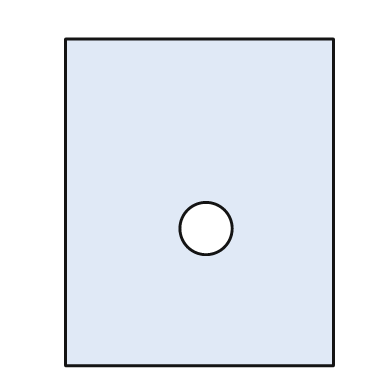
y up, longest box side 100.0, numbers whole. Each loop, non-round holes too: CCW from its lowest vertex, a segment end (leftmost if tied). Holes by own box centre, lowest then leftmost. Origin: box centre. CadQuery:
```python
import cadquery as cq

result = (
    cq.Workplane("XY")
    .moveTo(-41.0, -50.0)
    .lineTo(41.0, -50.0)
    .lineTo(41.0, 50.0)
    .lineTo(-41.0, 50.0)
    .close()
    .moveTo(2.0, -8.0)
    .circle(8.0)
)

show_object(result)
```